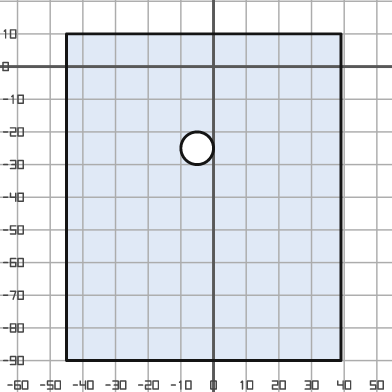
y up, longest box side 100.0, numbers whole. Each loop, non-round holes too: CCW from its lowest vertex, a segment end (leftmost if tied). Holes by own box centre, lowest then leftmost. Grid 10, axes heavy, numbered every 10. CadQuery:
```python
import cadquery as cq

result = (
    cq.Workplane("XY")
    .moveTo(-45.0, -90.0)
    .lineTo(39.0, -90.0)
    .lineTo(39.0, 10.0)
    .lineTo(-45.0, 10.0)
    .close()
    .moveTo(-5.0, -25.0)
    .circle(5.0)
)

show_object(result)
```